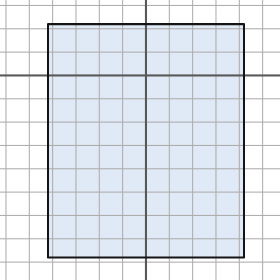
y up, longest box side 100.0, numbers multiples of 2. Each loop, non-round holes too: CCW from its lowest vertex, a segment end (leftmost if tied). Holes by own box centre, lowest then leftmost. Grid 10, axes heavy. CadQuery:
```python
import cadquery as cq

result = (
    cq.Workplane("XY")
    .moveTo(-42.0, -78.0)
    .lineTo(42.0, -78.0)
    .lineTo(42.0, 22.0)
    .lineTo(-42.0, 22.0)
    .close()
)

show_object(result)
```